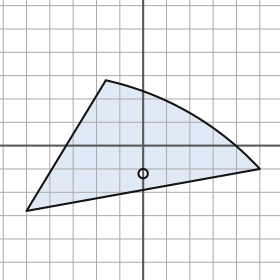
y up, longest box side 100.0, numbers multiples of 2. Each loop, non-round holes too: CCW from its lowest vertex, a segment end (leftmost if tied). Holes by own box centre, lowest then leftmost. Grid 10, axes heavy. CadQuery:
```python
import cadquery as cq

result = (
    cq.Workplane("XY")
    .moveTo(-50.0, -28.0)
    .lineTo(50.0, -10.0)
    .threePointArc((20.0, 14.0), (-16.0, 28.0))
    .close()
    .moveTo(0.0, -12.0)
    .circle(2.0)
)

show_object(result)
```